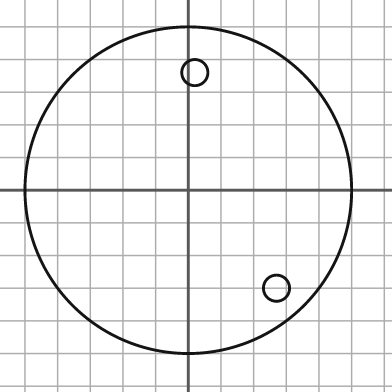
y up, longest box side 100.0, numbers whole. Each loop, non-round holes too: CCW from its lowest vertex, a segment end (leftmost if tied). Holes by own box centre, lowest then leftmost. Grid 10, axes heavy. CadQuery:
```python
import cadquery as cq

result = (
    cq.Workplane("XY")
    .moveTo(0.0, 0.0)
    .circle(50.0)
    .moveTo(27.0, -30.0)
    .circle(4.0)
    .moveTo(2.0, 36.0)
    .circle(4.0)
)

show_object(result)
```